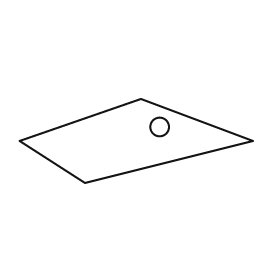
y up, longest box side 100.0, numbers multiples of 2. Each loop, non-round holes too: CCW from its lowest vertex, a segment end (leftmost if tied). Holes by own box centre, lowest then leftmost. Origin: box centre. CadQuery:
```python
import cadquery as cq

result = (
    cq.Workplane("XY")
    .moveTo(-22.0, -18.0)
    .lineTo(50.0, 0.0)
    .lineTo(2.0, 18.0)
    .lineTo(-50.0, 0.0)
    .close()
    .moveTo(10.0, 6.0)
    .circle(4.0)
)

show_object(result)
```